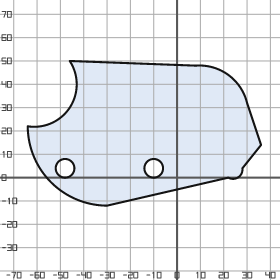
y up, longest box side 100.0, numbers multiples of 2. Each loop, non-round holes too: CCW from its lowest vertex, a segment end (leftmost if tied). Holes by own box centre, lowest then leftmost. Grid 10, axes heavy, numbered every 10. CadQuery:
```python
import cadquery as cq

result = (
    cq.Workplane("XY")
    .moveTo(-30.0, -12.0)
    .lineTo(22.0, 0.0)
    .threePointArc((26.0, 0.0), (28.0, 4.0))
    .lineTo(36.0, 14.0)
    .lineTo(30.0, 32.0)
    .threePointArc((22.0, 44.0), (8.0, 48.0))
    .lineTo(-46.0, 50.0)
    .threePointArc((-46.0, 30.0), (-64.0, 22.0))
    .threePointArc((-54.0, -2.0), (-30.0, -12.0))
    .close()
    .moveTo(-48.0, 4.0)
    .circle(4.0)
    .moveTo(-10.0, 4.0)
    .circle(4.0)
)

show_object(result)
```